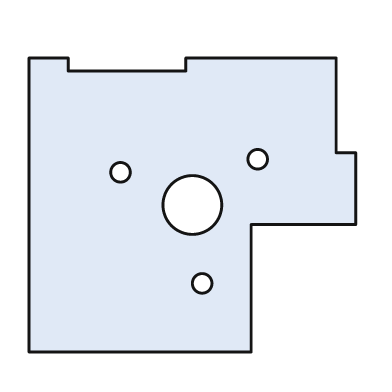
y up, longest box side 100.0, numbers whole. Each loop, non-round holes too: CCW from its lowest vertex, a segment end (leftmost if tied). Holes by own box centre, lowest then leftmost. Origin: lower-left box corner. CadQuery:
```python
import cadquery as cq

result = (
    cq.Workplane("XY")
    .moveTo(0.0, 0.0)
    .lineTo(68.0, 0.0)
    .lineTo(68.0, 39.0)
    .lineTo(100.0, 39.0)
    .lineTo(100.0, 61.0)
    .lineTo(94.0, 61.0)
    .lineTo(94.0, 90.0)
    .lineTo(48.0, 90.0)
    .lineTo(48.0, 86.0)
    .lineTo(12.0, 86.0)
    .lineTo(12.0, 90.0)
    .lineTo(0.0, 90.0)
    .close()
    .moveTo(53.0, 21.0)
    .circle(3.0)
    .moveTo(50.0, 45.0)
    .circle(9.0)
    .moveTo(28.0, 55.0)
    .circle(3.0)
    .moveTo(70.0, 59.0)
    .circle(3.0)
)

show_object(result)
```